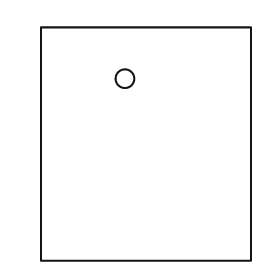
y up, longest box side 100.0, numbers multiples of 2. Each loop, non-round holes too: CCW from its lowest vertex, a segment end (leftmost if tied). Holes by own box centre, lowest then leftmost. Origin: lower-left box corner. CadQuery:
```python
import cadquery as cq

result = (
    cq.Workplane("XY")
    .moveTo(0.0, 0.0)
    .lineTo(90.0, 0.0)
    .lineTo(90.0, 100.0)
    .lineTo(0.0, 100.0)
    .close()
    .moveTo(36.0, 78.0)
    .circle(4.0)
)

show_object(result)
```